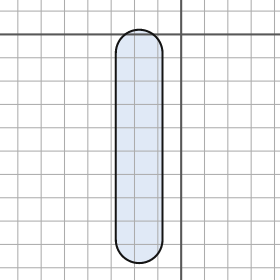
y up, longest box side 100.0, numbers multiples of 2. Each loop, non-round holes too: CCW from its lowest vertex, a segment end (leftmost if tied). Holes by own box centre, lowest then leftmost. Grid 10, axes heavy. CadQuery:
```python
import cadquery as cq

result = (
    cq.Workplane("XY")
    .moveTo(-28.0, -88.0)
    .threePointArc((-18.0, -98.0), (-8.0, -88.0))
    .lineTo(-8.0, -8.0)
    .threePointArc((-18.0, 2.0), (-28.0, -8.0))
    .close()
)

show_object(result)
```